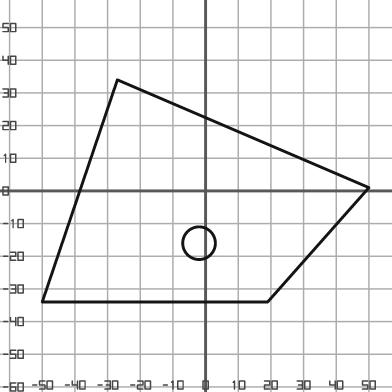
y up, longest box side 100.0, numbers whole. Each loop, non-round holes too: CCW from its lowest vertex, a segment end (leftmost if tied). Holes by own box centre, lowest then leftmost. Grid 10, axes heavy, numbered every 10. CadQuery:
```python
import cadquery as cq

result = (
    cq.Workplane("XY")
    .moveTo(-50.0, -34.0)
    .lineTo(19.0, -34.0)
    .lineTo(50.0, 1.0)
    .lineTo(-27.0, 34.0)
    .close()
    .moveTo(-2.0, -16.0)
    .circle(5.0)
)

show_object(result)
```